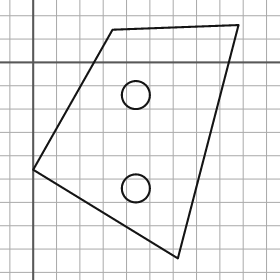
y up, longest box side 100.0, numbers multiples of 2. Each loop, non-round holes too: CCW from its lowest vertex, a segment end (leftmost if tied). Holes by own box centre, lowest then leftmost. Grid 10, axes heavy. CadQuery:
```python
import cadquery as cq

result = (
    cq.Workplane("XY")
    .moveTo(62.0, -84.0)
    .lineTo(88.0, 16.0)
    .lineTo(34.0, 14.0)
    .lineTo(0.0, -46.0)
    .close()
    .moveTo(44.0, -54.0)
    .circle(6.0)
    .moveTo(44.0, -14.0)
    .circle(6.0)
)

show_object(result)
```